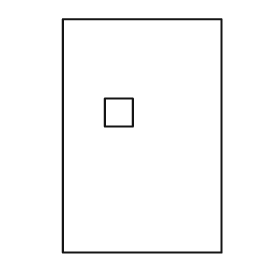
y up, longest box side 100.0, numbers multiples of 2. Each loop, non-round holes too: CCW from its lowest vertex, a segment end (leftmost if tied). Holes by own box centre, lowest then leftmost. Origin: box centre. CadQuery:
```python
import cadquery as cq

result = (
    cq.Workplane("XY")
    .moveTo(-34.0, -50.0)
    .lineTo(34.0, -50.0)
    .lineTo(34.0, 50.0)
    .lineTo(-34.0, 50.0)
    .close()
    .moveTo(-16.0, 4.0)
    .lineTo(-4.0, 4.0)
    .lineTo(-4.0, 16.0)
    .lineTo(-16.0, 16.0)
    .close()
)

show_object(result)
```